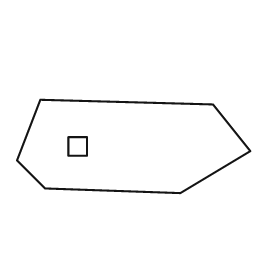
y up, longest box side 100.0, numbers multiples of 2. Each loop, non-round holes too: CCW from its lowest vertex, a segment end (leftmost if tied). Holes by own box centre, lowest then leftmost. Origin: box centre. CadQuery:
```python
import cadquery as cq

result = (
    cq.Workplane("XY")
    .moveTo(20.0, -20.0)
    .lineTo(50.0, -2.0)
    .lineTo(34.0, 18.0)
    .lineTo(-40.0, 20.0)
    .lineTo(-50.0, -6.0)
    .lineTo(-38.0, -18.0)
    .close()
    .moveTo(-28.0, -4.0)
    .lineTo(-20.0, -4.0)
    .lineTo(-20.0, 4.0)
    .lineTo(-28.0, 4.0)
    .close()
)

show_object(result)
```